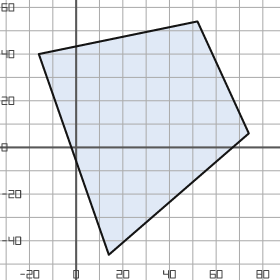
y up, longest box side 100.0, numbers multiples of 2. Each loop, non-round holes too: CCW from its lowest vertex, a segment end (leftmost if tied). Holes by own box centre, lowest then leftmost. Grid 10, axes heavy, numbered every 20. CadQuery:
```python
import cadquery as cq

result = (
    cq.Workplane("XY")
    .moveTo(14.0, -46.0)
    .lineTo(74.0, 6.0)
    .lineTo(52.0, 54.0)
    .lineTo(-16.0, 40.0)
    .close()
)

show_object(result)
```